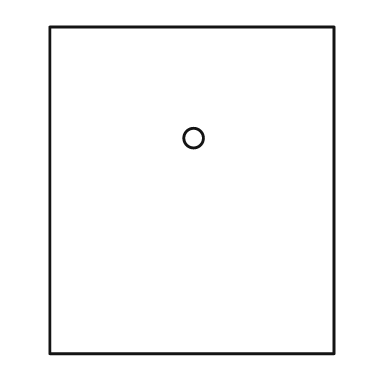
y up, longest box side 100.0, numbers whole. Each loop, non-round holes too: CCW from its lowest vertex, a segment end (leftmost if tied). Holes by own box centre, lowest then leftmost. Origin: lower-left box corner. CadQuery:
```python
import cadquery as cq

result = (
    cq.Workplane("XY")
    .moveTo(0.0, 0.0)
    .lineTo(87.0, 0.0)
    .lineTo(87.0, 100.0)
    .lineTo(0.0, 100.0)
    .close()
    .moveTo(44.0, 66.0)
    .circle(3.0)
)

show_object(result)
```